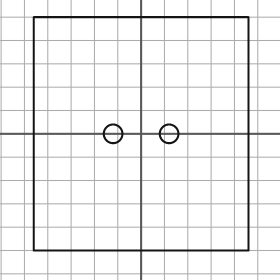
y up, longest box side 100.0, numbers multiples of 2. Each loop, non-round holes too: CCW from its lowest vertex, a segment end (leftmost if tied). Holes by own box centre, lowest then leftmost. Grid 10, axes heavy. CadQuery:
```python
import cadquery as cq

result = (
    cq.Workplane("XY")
    .moveTo(-46.0, -50.0)
    .lineTo(46.0, -50.0)
    .lineTo(46.0, 50.0)
    .lineTo(-46.0, 50.0)
    .close()
    .moveTo(-12.0, 0.0)
    .circle(4.0)
    .moveTo(12.0, 0.0)
    .circle(4.0)
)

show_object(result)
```